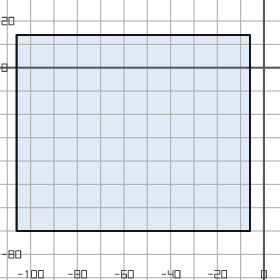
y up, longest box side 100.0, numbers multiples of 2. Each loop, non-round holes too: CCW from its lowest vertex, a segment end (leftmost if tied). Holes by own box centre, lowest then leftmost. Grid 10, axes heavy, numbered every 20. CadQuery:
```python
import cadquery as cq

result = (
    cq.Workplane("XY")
    .moveTo(-106.0, -70.0)
    .lineTo(-6.0, -70.0)
    .lineTo(-6.0, 14.0)
    .lineTo(-106.0, 14.0)
    .close()
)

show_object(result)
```